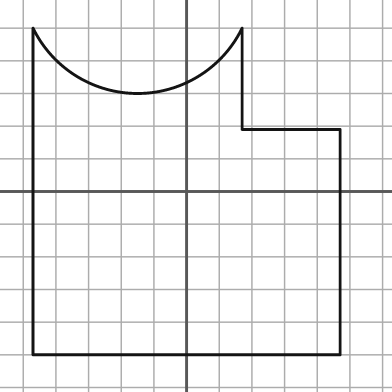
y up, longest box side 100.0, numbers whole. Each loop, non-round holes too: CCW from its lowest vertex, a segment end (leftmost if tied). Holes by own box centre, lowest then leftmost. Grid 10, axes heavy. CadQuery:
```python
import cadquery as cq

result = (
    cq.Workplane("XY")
    .moveTo(-47.0, -50.0)
    .lineTo(47.0, -50.0)
    .lineTo(47.0, 19.0)
    .lineTo(17.0, 19.0)
    .lineTo(17.0, 50.0)
    .threePointArc((-15.0, 30.0), (-47.0, 50.0))
    .close()
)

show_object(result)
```